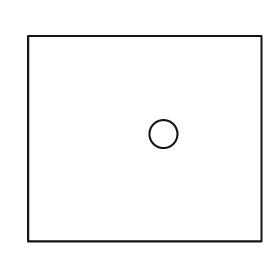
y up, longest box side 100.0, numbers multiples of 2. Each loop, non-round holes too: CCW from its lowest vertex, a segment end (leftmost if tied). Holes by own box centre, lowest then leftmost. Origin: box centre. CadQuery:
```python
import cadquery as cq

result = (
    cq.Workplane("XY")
    .moveTo(-50.0, -44.0)
    .lineTo(50.0, -44.0)
    .lineTo(50.0, 44.0)
    .lineTo(-50.0, 44.0)
    .close()
    .moveTo(8.0, 2.0)
    .circle(6.0)
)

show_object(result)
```